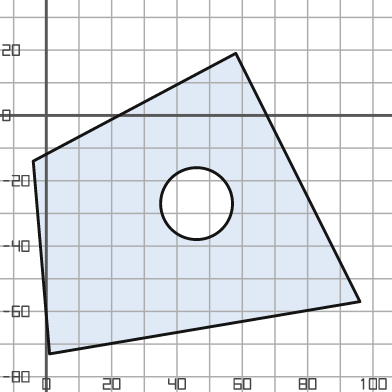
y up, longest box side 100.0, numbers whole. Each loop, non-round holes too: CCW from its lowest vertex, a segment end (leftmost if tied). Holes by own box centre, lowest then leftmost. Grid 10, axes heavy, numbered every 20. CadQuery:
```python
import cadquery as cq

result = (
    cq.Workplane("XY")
    .moveTo(1.0, -73.0)
    .lineTo(96.0, -57.0)
    .lineTo(58.0, 19.0)
    .lineTo(-4.0, -14.0)
    .close()
    .moveTo(46.0, -27.0)
    .circle(11.0)
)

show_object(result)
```